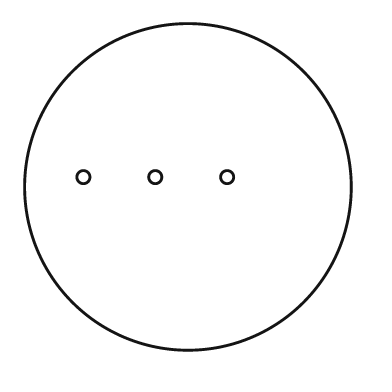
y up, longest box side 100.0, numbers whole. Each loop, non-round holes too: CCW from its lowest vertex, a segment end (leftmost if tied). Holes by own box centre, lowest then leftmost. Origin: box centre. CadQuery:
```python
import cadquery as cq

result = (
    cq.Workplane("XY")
    .moveTo(0.0, 0.0)
    .circle(50.0)
    .moveTo(-32.0, 3.0)
    .circle(2.0)
    .moveTo(-10.0, 3.0)
    .circle(2.0)
    .moveTo(12.0, 3.0)
    .circle(2.0)
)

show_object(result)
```